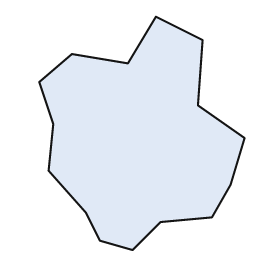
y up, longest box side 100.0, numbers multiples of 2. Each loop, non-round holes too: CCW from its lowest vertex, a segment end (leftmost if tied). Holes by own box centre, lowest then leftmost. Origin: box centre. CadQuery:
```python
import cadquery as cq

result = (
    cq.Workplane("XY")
    .moveTo(-4.0, -50.0)
    .lineTo(8.0, -38.0)
    .lineTo(30.0, -36.0)
    .lineTo(38.0, -22.0)
    .lineTo(44.0, -2.0)
    .lineTo(24.0, 12.0)
    .lineTo(26.0, 40.0)
    .lineTo(6.0, 50.0)
    .lineTo(-6.0, 30.0)
    .lineTo(-30.0, 34.0)
    .lineTo(-44.0, 22.0)
    .lineTo(-38.0, 4.0)
    .lineTo(-40.0, -16.0)
    .lineTo(-24.0, -34.0)
    .lineTo(-18.0, -46.0)
    .close()
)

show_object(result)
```